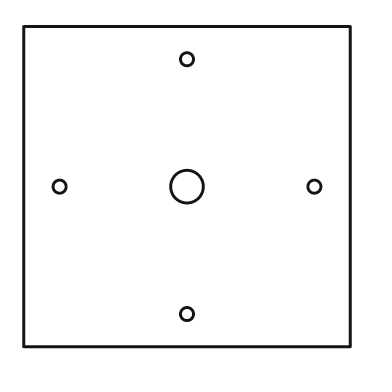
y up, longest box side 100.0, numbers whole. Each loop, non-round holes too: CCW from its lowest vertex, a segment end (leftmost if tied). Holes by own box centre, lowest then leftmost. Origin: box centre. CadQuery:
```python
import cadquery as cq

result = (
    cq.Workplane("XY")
    .moveTo(-50.0, -49.0)
    .lineTo(50.0, -49.0)
    .lineTo(50.0, 49.0)
    .lineTo(-50.0, 49.0)
    .close()
    .moveTo(0.0, -39.0)
    .circle(2.0)
    .moveTo(-39.0, 0.0)
    .circle(2.0)
    .moveTo(0.0, 0.0)
    .circle(5.0)
    .moveTo(39.0, 0.0)
    .circle(2.0)
    .moveTo(0.0, 39.0)
    .circle(2.0)
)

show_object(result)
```